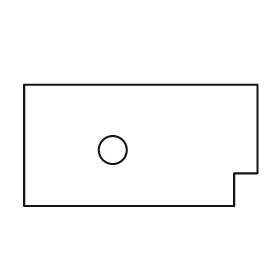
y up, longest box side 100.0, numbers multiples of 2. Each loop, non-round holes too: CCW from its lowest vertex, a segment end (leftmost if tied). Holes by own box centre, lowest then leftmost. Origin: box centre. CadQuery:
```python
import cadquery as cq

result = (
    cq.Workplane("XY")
    .moveTo(-50.0, -26.0)
    .lineTo(40.0, -26.0)
    .lineTo(40.0, -12.0)
    .lineTo(50.0, -12.0)
    .lineTo(50.0, 26.0)
    .lineTo(-50.0, 26.0)
    .close()
    .moveTo(-12.0, -2.0)
    .circle(6.0)
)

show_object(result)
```